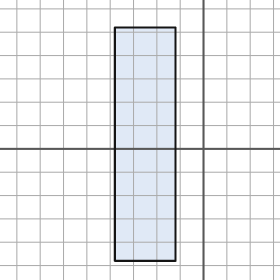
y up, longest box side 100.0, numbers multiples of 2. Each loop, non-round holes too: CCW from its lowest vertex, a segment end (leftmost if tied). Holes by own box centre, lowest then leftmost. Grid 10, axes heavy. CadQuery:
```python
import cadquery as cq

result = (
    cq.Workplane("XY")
    .moveTo(-38.0, -48.0)
    .lineTo(-12.0, -48.0)
    .lineTo(-12.0, 52.0)
    .lineTo(-38.0, 52.0)
    .close()
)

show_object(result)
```